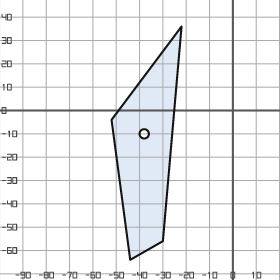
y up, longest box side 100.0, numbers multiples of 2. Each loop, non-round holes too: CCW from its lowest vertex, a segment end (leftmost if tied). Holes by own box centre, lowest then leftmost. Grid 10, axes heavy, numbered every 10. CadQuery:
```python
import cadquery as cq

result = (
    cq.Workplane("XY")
    .moveTo(-44.0, -64.0)
    .lineTo(-30.0, -56.0)
    .lineTo(-22.0, 36.0)
    .lineTo(-52.0, -4.0)
    .close()
    .moveTo(-38.0, -10.0)
    .circle(2.0)
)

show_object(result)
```